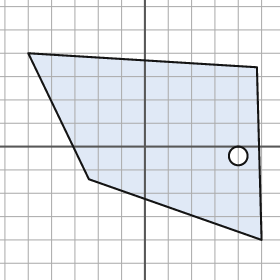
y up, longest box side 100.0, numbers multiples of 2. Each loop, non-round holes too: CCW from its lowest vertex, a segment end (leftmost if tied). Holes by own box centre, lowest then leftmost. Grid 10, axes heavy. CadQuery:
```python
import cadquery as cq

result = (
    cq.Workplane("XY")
    .moveTo(50.0, -40.0)
    .lineTo(48.0, 34.0)
    .lineTo(-50.0, 40.0)
    .lineTo(-24.0, -14.0)
    .close()
    .moveTo(40.0, -4.0)
    .circle(4.0)
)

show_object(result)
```